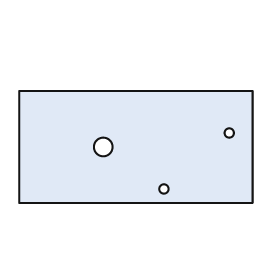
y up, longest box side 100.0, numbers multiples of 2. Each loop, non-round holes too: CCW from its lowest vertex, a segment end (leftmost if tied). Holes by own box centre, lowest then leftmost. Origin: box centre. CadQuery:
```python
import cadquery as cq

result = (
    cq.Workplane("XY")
    .moveTo(-50.0, -24.0)
    .lineTo(50.0, -24.0)
    .lineTo(50.0, 24.0)
    .lineTo(-50.0, 24.0)
    .close()
    .moveTo(12.0, -18.0)
    .circle(2.0)
    .moveTo(-14.0, 0.0)
    .circle(4.0)
    .moveTo(40.0, 6.0)
    .circle(2.0)
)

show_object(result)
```